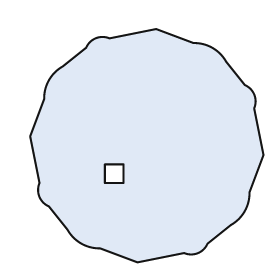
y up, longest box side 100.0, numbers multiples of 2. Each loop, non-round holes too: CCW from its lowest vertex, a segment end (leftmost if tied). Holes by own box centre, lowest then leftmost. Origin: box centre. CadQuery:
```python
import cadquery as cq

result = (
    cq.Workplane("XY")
    .moveTo(-4.0, -50.0)
    .lineTo(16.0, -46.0)
    .threePointArc((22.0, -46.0), (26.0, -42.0))
    .lineTo(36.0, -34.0)
    .threePointArc((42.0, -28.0), (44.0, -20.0))
    .lineTo(50.0, -4.0)
    .lineTo(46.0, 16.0)
    .threePointArc((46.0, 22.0), (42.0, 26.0))
    .lineTo(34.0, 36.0)
    .threePointArc((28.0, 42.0), (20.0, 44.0))
    .lineTo(4.0, 50.0)
    .lineTo(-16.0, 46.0)
    .threePointArc((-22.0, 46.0), (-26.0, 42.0))
    .lineTo(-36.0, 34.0)
    .threePointArc((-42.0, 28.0), (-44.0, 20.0))
    .lineTo(-50.0, 4.0)
    .lineTo(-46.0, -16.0)
    .threePointArc((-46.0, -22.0), (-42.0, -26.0))
    .lineTo(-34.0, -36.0)
    .threePointArc((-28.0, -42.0), (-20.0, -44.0))
    .close()
    .moveTo(-18.0, -16.0)
    .lineTo(-10.0, -16.0)
    .lineTo(-10.0, -8.0)
    .lineTo(-18.0, -8.0)
    .close()
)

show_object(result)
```